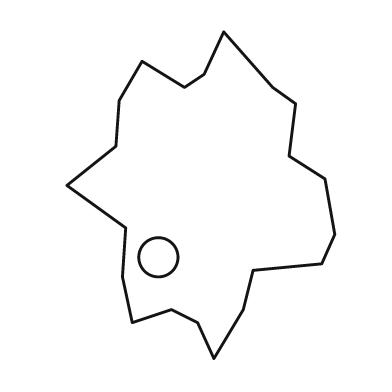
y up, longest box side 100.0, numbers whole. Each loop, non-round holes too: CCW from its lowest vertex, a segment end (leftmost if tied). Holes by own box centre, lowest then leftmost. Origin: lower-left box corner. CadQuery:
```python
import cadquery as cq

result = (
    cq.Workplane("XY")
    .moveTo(45.0, 0.0)
    .lineTo(54.0, 15.0)
    .lineTo(57.0, 27.0)
    .lineTo(78.0, 29.0)
    .lineTo(82.0, 38.0)
    .lineTo(79.0, 55.0)
    .lineTo(68.0, 62.0)
    .lineTo(70.0, 78.0)
    .lineTo(63.0, 83.0)
    .lineTo(48.0, 100.0)
    .lineTo(42.0, 87.0)
    .lineTo(36.0, 83.0)
    .lineTo(23.0, 91.0)
    .lineTo(16.0, 79.0)
    .lineTo(15.0, 65.0)
    .lineTo(0.0, 53.0)
    .lineTo(18.0, 40.0)
    .lineTo(17.0, 25.0)
    .lineTo(20.0, 11.0)
    .lineTo(32.0, 15.0)
    .lineTo(40.0, 11.0)
    .close()
    .moveTo(28.0, 31.0)
    .circle(6.0)
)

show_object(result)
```